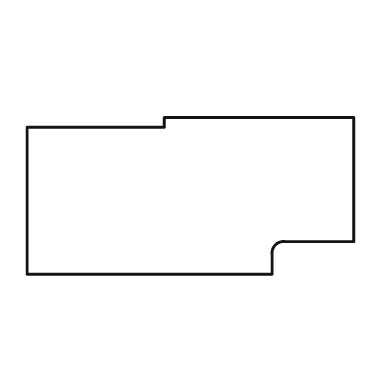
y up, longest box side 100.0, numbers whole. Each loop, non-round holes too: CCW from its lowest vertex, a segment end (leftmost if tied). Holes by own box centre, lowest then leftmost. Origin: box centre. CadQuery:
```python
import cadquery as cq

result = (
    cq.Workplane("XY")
    .moveTo(-50.0, -24.0)
    .lineTo(25.0, -24.0)
    .lineTo(25.0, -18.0)
    .threePointArc((26.0, -15.0), (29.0, -14.0))
    .lineTo(50.0, -14.0)
    .lineTo(50.0, 24.0)
    .lineTo(-8.0, 24.0)
    .lineTo(-8.0, 21.0)
    .lineTo(-50.0, 21.0)
    .close()
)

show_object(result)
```